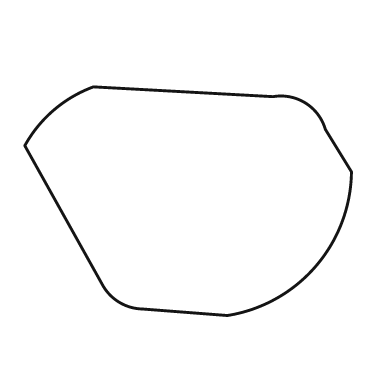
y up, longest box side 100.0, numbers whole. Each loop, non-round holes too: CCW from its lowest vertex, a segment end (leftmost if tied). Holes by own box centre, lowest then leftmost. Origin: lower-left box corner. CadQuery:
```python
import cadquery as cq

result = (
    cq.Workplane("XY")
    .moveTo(62.0, 0.0)
    .threePointArc((89.0, 15.0), (100.0, 44.0))
    .lineTo(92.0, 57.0)
    .threePointArc((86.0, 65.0), (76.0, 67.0))
    .lineTo(21.0, 70.0)
    .threePointArc((9.0, 63.0), (0.0, 52.0))
    .lineTo(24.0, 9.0)
    .threePointArc((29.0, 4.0), (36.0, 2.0))
    .close()
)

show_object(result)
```